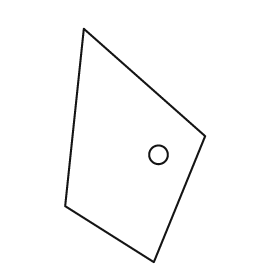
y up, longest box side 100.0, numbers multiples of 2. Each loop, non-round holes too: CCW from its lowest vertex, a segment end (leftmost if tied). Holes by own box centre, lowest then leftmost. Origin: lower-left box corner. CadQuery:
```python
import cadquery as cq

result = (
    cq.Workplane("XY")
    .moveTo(38.0, 0.0)
    .lineTo(60.0, 54.0)
    .lineTo(8.0, 100.0)
    .lineTo(0.0, 24.0)
    .close()
    .moveTo(40.0, 46.0)
    .circle(4.0)
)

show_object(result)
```